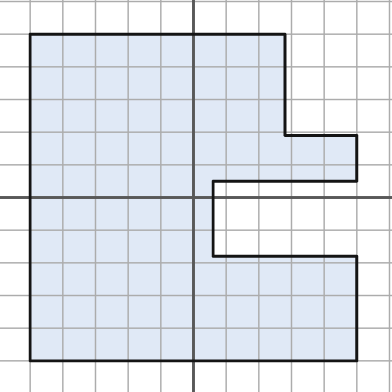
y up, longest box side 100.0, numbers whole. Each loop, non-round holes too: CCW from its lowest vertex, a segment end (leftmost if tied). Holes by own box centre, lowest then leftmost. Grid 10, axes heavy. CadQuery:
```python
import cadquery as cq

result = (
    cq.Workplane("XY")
    .moveTo(-50.0, -50.0)
    .lineTo(50.0, -50.0)
    .lineTo(50.0, -18.0)
    .lineTo(6.0, -18.0)
    .lineTo(6.0, 5.0)
    .lineTo(50.0, 5.0)
    .lineTo(50.0, 19.0)
    .lineTo(28.0, 19.0)
    .lineTo(28.0, 50.0)
    .lineTo(-50.0, 50.0)
    .close()
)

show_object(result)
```